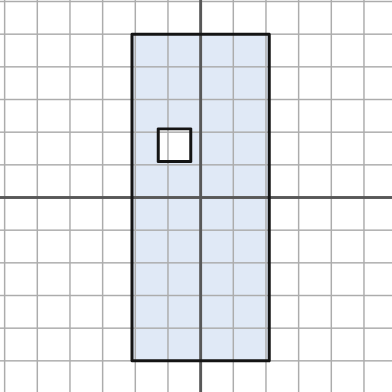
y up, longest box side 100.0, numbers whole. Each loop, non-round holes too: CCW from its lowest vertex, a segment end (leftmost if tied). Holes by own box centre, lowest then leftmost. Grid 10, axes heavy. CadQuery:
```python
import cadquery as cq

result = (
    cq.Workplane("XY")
    .moveTo(-21.0, -50.0)
    .lineTo(21.0, -50.0)
    .lineTo(21.0, 50.0)
    .lineTo(-21.0, 50.0)
    .close()
    .moveTo(-13.0, 11.0)
    .lineTo(-3.0, 11.0)
    .lineTo(-3.0, 21.0)
    .lineTo(-13.0, 21.0)
    .close()
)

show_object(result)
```